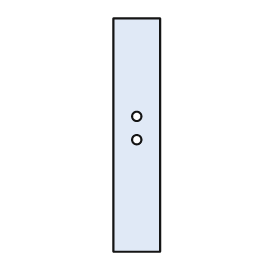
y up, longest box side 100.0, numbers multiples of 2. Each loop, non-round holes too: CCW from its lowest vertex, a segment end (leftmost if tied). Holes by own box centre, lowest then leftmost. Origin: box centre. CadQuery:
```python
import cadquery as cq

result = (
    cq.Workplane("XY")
    .moveTo(-10.0, -50.0)
    .lineTo(10.0, -50.0)
    .lineTo(10.0, 50.0)
    .lineTo(-10.0, 50.0)
    .close()
    .moveTo(0.0, -2.0)
    .circle(2.0)
    .moveTo(0.0, 8.0)
    .circle(2.0)
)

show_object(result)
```